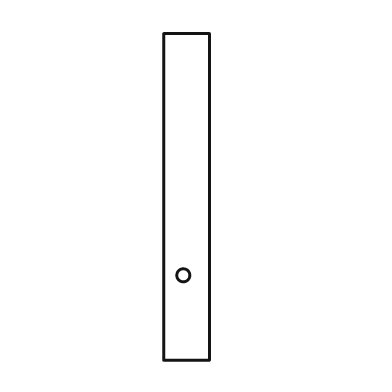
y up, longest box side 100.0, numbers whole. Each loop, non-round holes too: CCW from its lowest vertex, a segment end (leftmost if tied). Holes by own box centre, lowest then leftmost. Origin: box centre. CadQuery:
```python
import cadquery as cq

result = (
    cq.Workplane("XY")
    .moveTo(-7.0, -50.0)
    .lineTo(7.0, -50.0)
    .lineTo(7.0, 50.0)
    .lineTo(-7.0, 50.0)
    .close()
    .moveTo(-1.0, -24.0)
    .circle(2.0)
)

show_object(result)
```